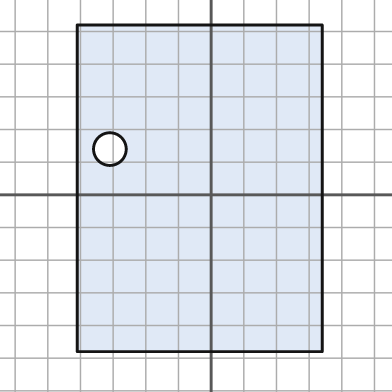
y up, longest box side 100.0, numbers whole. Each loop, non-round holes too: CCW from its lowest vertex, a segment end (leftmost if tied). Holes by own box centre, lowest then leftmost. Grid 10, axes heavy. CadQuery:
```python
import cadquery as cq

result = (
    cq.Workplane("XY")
    .moveTo(-41.0, -48.0)
    .lineTo(34.0, -48.0)
    .lineTo(34.0, 52.0)
    .lineTo(-41.0, 52.0)
    .close()
    .moveTo(-31.0, 14.0)
    .circle(5.0)
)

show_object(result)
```